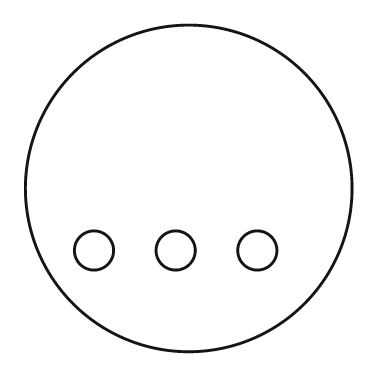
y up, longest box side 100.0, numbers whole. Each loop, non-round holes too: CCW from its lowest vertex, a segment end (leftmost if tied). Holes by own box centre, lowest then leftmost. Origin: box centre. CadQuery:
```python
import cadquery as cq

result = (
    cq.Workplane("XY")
    .moveTo(0.0, 0.0)
    .circle(50.0)
    .moveTo(-29.0, -19.0)
    .circle(6.0)
    .moveTo(-4.0, -19.0)
    .circle(6.0)
    .moveTo(21.0, -19.0)
    .circle(6.0)
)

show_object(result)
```